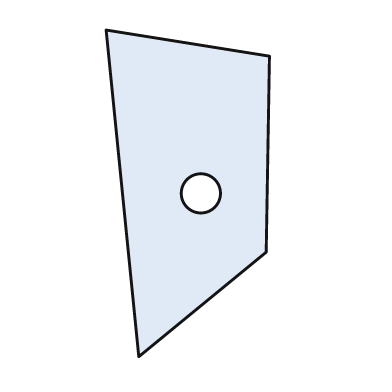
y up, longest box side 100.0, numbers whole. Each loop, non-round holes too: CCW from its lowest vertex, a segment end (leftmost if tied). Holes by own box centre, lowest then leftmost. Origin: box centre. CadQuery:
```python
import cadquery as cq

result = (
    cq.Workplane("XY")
    .moveTo(-15.0, -50.0)
    .lineTo(24.0, -18.0)
    .lineTo(25.0, 42.0)
    .lineTo(-25.0, 50.0)
    .close()
    .moveTo(4.0, 0.0)
    .circle(6.0)
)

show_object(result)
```